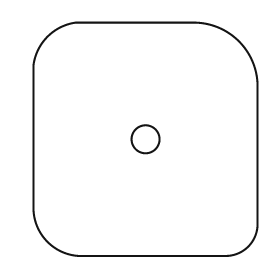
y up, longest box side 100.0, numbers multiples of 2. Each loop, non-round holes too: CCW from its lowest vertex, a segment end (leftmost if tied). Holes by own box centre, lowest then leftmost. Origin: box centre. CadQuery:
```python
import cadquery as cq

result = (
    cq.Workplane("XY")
    .moveTo(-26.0, -50.0)
    .lineTo(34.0, -50.0)
    .threePointArc((44.0, -46.0), (48.0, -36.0))
    .lineTo(48.0, 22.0)
    .threePointArc((40.0, 42.0), (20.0, 50.0))
    .lineTo(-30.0, 50.0)
    .threePointArc((-42.0, 44.0), (-48.0, 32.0))
    .lineTo(-48.0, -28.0)
    .threePointArc((-42.0, -44.0), (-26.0, -50.0))
    .close()
    .moveTo(0.0, 0.0)
    .circle(6.0)
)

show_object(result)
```